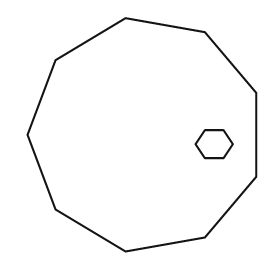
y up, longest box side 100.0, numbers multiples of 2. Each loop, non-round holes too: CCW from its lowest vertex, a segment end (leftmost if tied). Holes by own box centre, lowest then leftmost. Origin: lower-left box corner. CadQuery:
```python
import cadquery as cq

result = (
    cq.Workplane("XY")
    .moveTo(42.0, 0.0)
    .lineTo(76.0, 6.0)
    .lineTo(98.0, 32.0)
    .lineTo(98.0, 68.0)
    .lineTo(76.0, 94.0)
    .lineTo(42.0, 100.0)
    .lineTo(12.0, 82.0)
    .lineTo(0.0, 50.0)
    .lineTo(12.0, 18.0)
    .close()
    .moveTo(76.0, 40.0)
    .lineTo(84.0, 40.0)
    .lineTo(88.0, 46.0)
    .lineTo(84.0, 52.0)
    .lineTo(76.0, 52.0)
    .lineTo(72.0, 46.0)
    .close()
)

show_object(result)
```